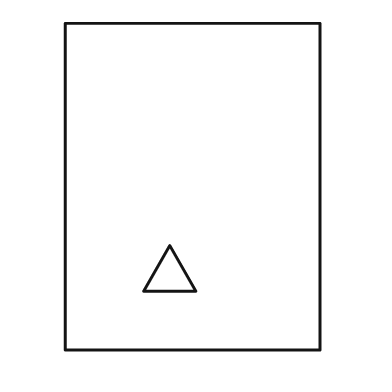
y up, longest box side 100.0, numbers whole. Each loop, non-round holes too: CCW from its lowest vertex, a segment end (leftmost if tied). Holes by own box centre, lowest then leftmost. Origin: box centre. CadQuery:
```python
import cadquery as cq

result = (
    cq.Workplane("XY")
    .moveTo(-39.0, -50.0)
    .lineTo(39.0, -50.0)
    .lineTo(39.0, 50.0)
    .lineTo(-39.0, 50.0)
    .close()
    .moveTo(-15.0, -32.0)
    .lineTo(1.0, -32.0)
    .lineTo(-7.0, -18.0)
    .close()
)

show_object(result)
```